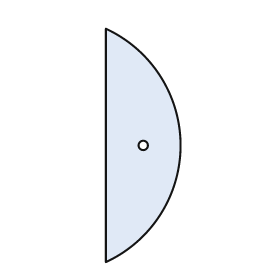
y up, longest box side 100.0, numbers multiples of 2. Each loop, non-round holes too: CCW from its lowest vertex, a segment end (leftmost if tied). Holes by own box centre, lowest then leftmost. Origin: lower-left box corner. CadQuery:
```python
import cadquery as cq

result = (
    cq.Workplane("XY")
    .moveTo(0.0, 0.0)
    .threePointArc((32.0, 50.0), (0.0, 100.0))
    .close()
    .moveTo(16.0, 50.0)
    .circle(2.0)
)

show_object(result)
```